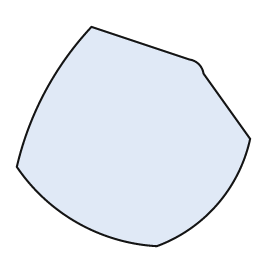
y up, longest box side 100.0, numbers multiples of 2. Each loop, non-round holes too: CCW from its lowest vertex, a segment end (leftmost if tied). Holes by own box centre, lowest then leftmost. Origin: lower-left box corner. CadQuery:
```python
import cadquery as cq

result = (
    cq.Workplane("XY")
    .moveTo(60.0, 0.0)
    .threePointArc((86.0, 18.0), (100.0, 46.0))
    .lineTo(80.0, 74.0)
    .threePointArc((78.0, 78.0), (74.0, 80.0))
    .lineTo(32.0, 94.0)
    .threePointArc((12.0, 66.0), (0.0, 34.0))
    .threePointArc((26.0, 10.0), (60.0, 0.0))
    .close()
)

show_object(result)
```